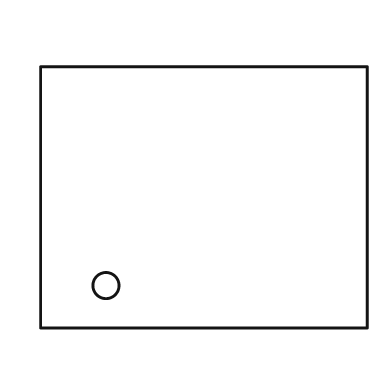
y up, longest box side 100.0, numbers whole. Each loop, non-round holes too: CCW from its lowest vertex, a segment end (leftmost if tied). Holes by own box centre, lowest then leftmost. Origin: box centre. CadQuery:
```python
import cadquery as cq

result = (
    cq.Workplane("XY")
    .moveTo(-50.0, -40.0)
    .lineTo(50.0, -40.0)
    .lineTo(50.0, 40.0)
    .lineTo(-50.0, 40.0)
    .close()
    .moveTo(-30.0, -27.0)
    .circle(4.0)
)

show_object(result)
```